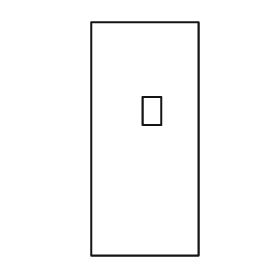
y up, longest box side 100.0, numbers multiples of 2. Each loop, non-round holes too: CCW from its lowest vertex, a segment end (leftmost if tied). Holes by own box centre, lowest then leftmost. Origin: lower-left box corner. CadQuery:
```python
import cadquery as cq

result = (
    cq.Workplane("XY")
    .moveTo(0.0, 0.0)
    .lineTo(46.0, 0.0)
    .lineTo(46.0, 100.0)
    .lineTo(0.0, 100.0)
    .close()
    .moveTo(22.0, 56.0)
    .lineTo(30.0, 56.0)
    .lineTo(30.0, 68.0)
    .lineTo(22.0, 68.0)
    .close()
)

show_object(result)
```